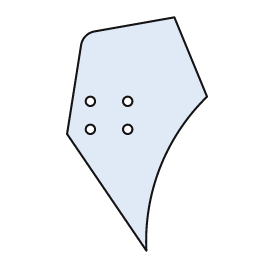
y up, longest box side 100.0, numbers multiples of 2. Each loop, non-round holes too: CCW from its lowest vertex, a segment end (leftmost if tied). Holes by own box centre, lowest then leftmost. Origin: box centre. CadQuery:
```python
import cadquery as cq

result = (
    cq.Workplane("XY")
    .moveTo(4.0, -50.0)
    .threePointArc((10.0, -14.0), (30.0, 16.0))
    .lineTo(16.0, 50.0)
    .lineTo(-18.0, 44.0)
    .threePointArc((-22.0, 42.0), (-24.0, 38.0))
    .lineTo(-30.0, 0.0)
    .close()
    .moveTo(-20.0, 2.0)
    .circle(2.0)
    .moveTo(-4.0, 2.0)
    .circle(2.0)
    .moveTo(-20.0, 14.0)
    .circle(2.0)
    .moveTo(-4.0, 14.0)
    .circle(2.0)
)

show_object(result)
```